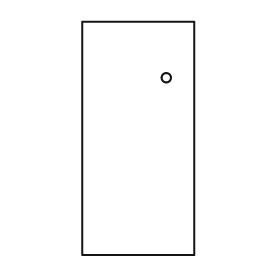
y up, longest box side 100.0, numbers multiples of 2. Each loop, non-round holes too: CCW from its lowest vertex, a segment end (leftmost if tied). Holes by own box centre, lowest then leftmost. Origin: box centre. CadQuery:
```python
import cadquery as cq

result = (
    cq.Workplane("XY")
    .moveTo(-24.0, -50.0)
    .lineTo(24.0, -50.0)
    .lineTo(24.0, 50.0)
    .lineTo(-24.0, 50.0)
    .close()
    .moveTo(12.0, 26.0)
    .circle(2.0)
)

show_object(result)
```